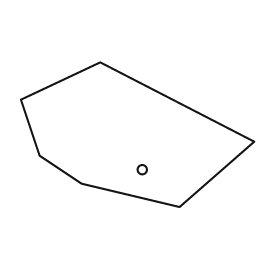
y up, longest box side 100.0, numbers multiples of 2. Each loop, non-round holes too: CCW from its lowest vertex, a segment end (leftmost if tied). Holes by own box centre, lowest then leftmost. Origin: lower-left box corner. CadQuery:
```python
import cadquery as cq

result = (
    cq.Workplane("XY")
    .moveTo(68.0, 0.0)
    .lineTo(100.0, 28.0)
    .lineTo(34.0, 62.0)
    .lineTo(0.0, 46.0)
    .lineTo(8.0, 22.0)
    .lineTo(26.0, 10.0)
    .close()
    .moveTo(52.0, 16.0)
    .circle(2.0)
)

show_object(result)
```